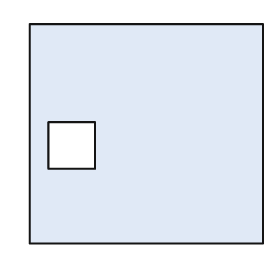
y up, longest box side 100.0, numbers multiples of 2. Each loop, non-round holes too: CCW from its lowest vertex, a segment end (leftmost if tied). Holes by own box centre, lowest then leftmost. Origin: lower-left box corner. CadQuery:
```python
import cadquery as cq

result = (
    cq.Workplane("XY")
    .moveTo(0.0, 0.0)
    .lineTo(100.0, 0.0)
    .lineTo(100.0, 94.0)
    .lineTo(0.0, 94.0)
    .close()
    .moveTo(8.0, 32.0)
    .lineTo(28.0, 32.0)
    .lineTo(28.0, 52.0)
    .lineTo(8.0, 52.0)
    .close()
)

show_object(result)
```